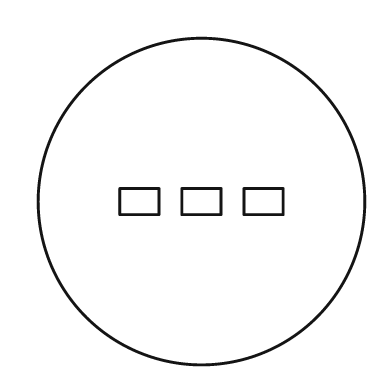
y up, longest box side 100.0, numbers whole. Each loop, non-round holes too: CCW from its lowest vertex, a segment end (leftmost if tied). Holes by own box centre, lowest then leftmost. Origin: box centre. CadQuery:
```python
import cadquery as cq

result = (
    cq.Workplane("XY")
    .moveTo(0.0, 0.0)
    .circle(50.0)
    .moveTo(-25.0, -4.0)
    .lineTo(-13.0, -4.0)
    .lineTo(-13.0, 4.0)
    .lineTo(-25.0, 4.0)
    .close()
    .moveTo(-6.0, -4.0)
    .lineTo(6.0, -4.0)
    .lineTo(6.0, 4.0)
    .lineTo(-6.0, 4.0)
    .close()
    .moveTo(13.0, -4.0)
    .lineTo(25.0, -4.0)
    .lineTo(25.0, 4.0)
    .lineTo(13.0, 4.0)
    .close()
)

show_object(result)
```